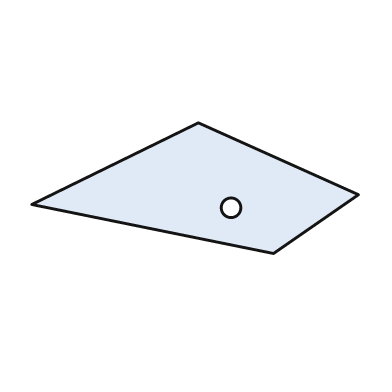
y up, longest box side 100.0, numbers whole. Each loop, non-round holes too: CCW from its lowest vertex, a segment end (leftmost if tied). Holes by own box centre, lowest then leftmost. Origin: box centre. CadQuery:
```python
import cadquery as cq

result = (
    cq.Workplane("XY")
    .moveTo(24.0, -20.0)
    .lineTo(50.0, -2.0)
    .lineTo(1.0, 20.0)
    .lineTo(-50.0, -5.0)
    .close()
    .moveTo(11.0, -6.0)
    .circle(3.0)
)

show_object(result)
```